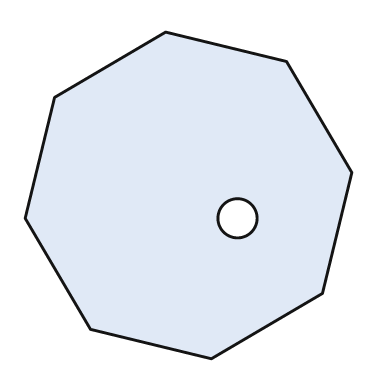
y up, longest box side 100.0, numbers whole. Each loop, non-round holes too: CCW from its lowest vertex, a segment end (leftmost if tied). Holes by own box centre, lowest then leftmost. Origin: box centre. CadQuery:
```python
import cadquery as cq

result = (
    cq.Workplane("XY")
    .moveTo(7.0, -50.0)
    .lineTo(41.0, -30.0)
    .lineTo(50.0, 7.0)
    .lineTo(30.0, 41.0)
    .lineTo(-7.0, 50.0)
    .lineTo(-41.0, 30.0)
    .lineTo(-50.0, -7.0)
    .lineTo(-30.0, -41.0)
    .close()
    .moveTo(15.0, -7.0)
    .circle(6.0)
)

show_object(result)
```